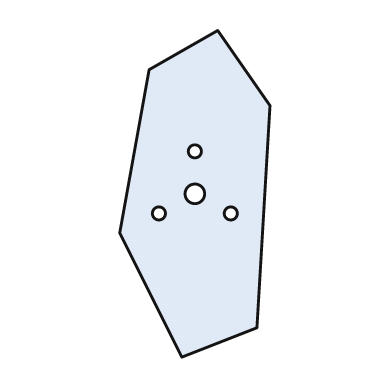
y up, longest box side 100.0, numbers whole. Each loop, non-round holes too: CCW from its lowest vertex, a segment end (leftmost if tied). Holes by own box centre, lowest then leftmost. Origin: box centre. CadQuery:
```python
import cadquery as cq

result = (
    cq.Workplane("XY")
    .moveTo(-4.0, -50.0)
    .lineTo(19.0, -41.0)
    .lineTo(23.0, 27.0)
    .lineTo(7.0, 50.0)
    .lineTo(-14.0, 38.0)
    .lineTo(-23.0, -12.0)
    .close()
    .moveTo(-11.0, -6.0)
    .circle(2.0)
    .moveTo(11.0, -6.0)
    .circle(2.0)
    .moveTo(0.0, 0.0)
    .circle(3.0)
    .moveTo(0.0, 13.0)
    .circle(2.0)
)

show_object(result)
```